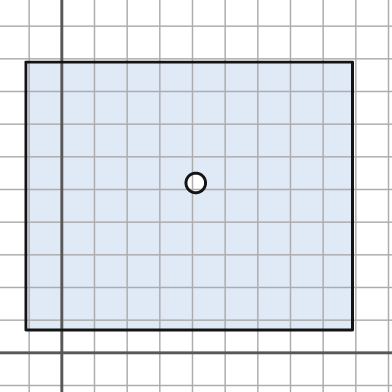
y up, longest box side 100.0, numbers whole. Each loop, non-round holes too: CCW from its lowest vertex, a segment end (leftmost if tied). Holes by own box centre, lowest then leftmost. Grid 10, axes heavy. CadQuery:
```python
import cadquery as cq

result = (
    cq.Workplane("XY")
    .moveTo(-11.0, 7.0)
    .lineTo(89.0, 7.0)
    .lineTo(89.0, 89.0)
    .lineTo(-11.0, 89.0)
    .close()
    .moveTo(41.0, 52.0)
    .circle(3.0)
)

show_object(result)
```